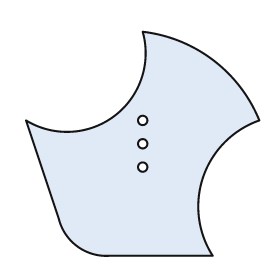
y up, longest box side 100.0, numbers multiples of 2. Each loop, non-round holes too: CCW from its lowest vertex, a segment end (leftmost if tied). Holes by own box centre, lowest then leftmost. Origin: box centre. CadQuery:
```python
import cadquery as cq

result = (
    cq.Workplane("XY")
    .moveTo(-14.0, -48.0)
    .lineTo(30.0, -48.0)
    .threePointArc((26.0, -14.0), (50.0, 10.0))
    .threePointArc((30.0, 36.0), (0.0, 48.0))
    .threePointArc((-12.0, 12.0), (-50.0, 10.0))
    .lineTo(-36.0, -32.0)
    .threePointArc((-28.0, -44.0), (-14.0, -48.0))
    .close()
    .moveTo(0.0, -10.0)
    .circle(2.0)
    .moveTo(0.0, 0.0)
    .circle(2.0)
    .moveTo(0.0, 10.0)
    .circle(2.0)
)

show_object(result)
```